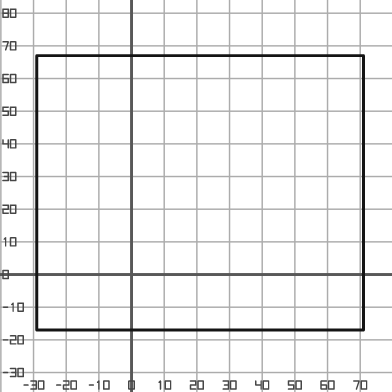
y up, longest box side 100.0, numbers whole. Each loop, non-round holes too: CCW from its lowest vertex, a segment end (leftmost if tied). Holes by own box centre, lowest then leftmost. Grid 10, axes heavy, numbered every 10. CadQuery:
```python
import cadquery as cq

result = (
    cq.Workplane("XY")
    .moveTo(-29.0, -17.0)
    .lineTo(71.0, -17.0)
    .lineTo(71.0, 67.0)
    .lineTo(-29.0, 67.0)
    .close()
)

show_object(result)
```